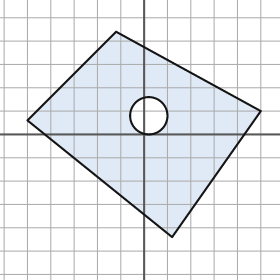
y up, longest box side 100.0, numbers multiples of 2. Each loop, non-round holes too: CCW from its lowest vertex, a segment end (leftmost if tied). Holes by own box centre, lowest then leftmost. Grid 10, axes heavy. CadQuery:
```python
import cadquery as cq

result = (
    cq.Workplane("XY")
    .moveTo(12.0, -44.0)
    .lineTo(50.0, 10.0)
    .lineTo(-12.0, 44.0)
    .lineTo(-50.0, 6.0)
    .close()
    .moveTo(2.0, 8.0)
    .circle(8.0)
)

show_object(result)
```